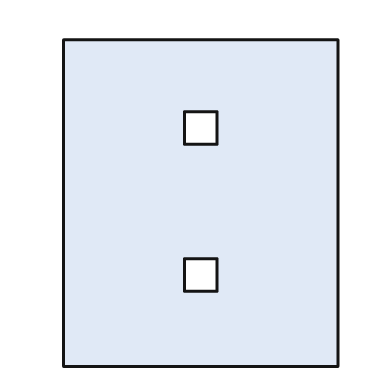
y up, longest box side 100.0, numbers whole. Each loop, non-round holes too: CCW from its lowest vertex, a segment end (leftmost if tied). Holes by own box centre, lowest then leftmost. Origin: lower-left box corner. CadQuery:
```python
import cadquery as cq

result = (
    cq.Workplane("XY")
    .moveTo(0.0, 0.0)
    .lineTo(84.0, 0.0)
    .lineTo(84.0, 100.0)
    .lineTo(0.0, 100.0)
    .close()
    .moveTo(37.0, 23.0)
    .lineTo(47.0, 23.0)
    .lineTo(47.0, 33.0)
    .lineTo(37.0, 33.0)
    .close()
    .moveTo(37.0, 68.0)
    .lineTo(47.0, 68.0)
    .lineTo(47.0, 78.0)
    .lineTo(37.0, 78.0)
    .close()
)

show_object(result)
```